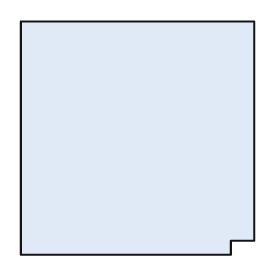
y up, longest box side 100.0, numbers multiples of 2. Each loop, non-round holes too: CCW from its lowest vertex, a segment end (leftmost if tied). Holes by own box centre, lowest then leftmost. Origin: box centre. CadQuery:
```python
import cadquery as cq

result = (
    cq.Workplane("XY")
    .moveTo(-50.0, -50.0)
    .lineTo(40.0, -50.0)
    .lineTo(40.0, -44.0)
    .lineTo(50.0, -44.0)
    .lineTo(50.0, 50.0)
    .lineTo(-50.0, 50.0)
    .close()
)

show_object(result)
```